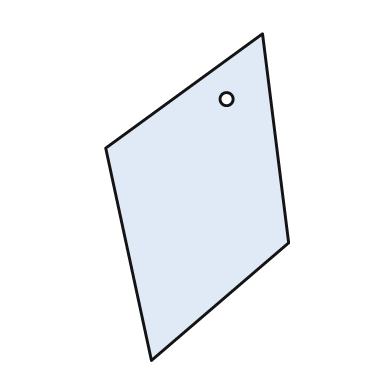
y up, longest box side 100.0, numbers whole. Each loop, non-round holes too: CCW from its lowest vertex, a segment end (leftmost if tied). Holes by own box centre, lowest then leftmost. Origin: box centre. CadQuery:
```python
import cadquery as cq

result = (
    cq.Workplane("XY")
    .moveTo(-14.0, -50.0)
    .lineTo(28.0, -14.0)
    .lineTo(20.0, 50.0)
    .lineTo(-28.0, 15.0)
    .close()
    .moveTo(9.0, 30.0)
    .circle(2.0)
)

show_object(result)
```